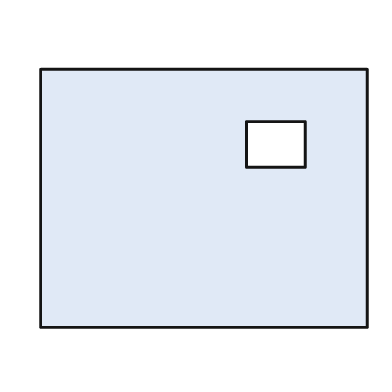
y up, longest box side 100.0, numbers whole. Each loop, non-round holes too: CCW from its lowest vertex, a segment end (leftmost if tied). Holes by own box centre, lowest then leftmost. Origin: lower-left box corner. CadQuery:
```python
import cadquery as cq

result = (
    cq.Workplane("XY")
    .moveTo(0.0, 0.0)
    .lineTo(100.0, 0.0)
    .lineTo(100.0, 79.0)
    .lineTo(0.0, 79.0)
    .close()
    .moveTo(63.0, 49.0)
    .lineTo(81.0, 49.0)
    .lineTo(81.0, 63.0)
    .lineTo(63.0, 63.0)
    .close()
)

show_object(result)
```